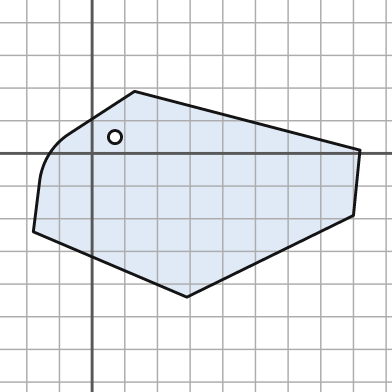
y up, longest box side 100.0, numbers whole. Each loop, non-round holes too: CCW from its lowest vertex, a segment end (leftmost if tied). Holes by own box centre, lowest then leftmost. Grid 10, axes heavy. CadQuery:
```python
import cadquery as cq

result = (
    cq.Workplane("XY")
    .moveTo(29.0, -44.0)
    .lineTo(80.0, -19.0)
    .lineTo(82.0, 1.0)
    .lineTo(13.0, 19.0)
    .lineTo(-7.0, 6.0)
    .threePointArc((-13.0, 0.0), (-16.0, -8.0))
    .lineTo(-18.0, -24.0)
    .close()
    .moveTo(7.0, 5.0)
    .circle(2.0)
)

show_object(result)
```